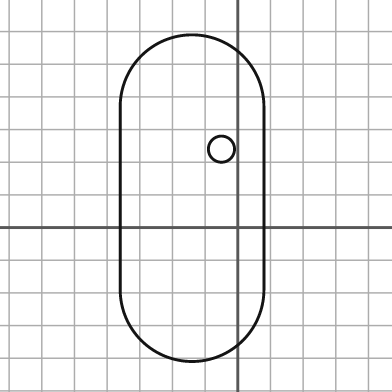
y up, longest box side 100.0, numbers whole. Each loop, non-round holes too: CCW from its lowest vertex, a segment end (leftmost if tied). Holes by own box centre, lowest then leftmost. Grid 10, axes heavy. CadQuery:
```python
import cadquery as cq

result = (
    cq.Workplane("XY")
    .moveTo(-36.0, -19.0)
    .threePointArc((-14.0, -41.0), (8.0, -19.0))
    .lineTo(8.0, 37.0)
    .threePointArc((-14.0, 59.0), (-36.0, 37.0))
    .close()
    .moveTo(-5.0, 24.0)
    .circle(4.0)
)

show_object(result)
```